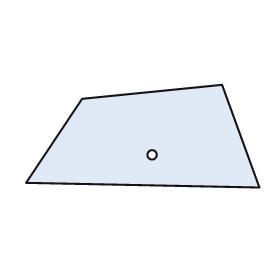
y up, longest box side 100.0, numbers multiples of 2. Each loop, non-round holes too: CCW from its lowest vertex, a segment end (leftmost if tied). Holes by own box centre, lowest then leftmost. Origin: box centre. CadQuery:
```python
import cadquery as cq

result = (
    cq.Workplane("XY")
    .moveTo(50.0, -22.0)
    .lineTo(34.0, 22.0)
    .lineTo(-26.0, 16.0)
    .lineTo(-50.0, -20.0)
    .close()
    .moveTo(4.0, -8.0)
    .circle(2.0)
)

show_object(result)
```